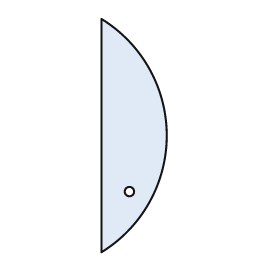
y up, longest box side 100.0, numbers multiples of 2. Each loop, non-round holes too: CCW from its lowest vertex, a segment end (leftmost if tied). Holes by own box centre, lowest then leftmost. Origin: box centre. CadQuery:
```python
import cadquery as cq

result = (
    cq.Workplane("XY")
    .moveTo(-14.0, -50.0)
    .threePointArc((14.0, 0.0), (-14.0, 50.0))
    .close()
    .moveTo(-2.0, -24.0)
    .circle(2.0)
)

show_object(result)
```